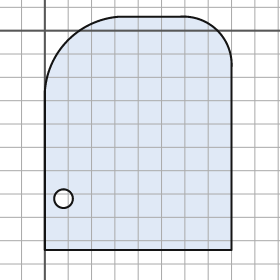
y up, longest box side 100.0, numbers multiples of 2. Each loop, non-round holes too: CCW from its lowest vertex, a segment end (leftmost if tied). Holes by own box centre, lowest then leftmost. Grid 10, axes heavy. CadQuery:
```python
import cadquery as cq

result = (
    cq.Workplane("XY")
    .moveTo(0.0, -94.0)
    .lineTo(80.0, -94.0)
    .lineTo(80.0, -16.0)
    .threePointArc((74.0, 0.0), (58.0, 6.0))
    .lineTo(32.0, 6.0)
    .threePointArc((10.0, -4.0), (0.0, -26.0))
    .close()
    .moveTo(8.0, -72.0)
    .circle(4.0)
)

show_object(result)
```